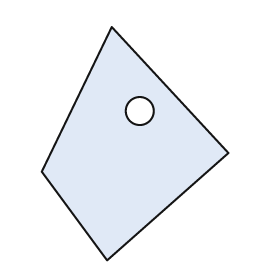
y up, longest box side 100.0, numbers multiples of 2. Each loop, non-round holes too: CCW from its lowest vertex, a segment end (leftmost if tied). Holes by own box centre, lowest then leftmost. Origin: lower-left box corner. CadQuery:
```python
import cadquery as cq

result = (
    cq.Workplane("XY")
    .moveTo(28.0, 0.0)
    .lineTo(80.0, 46.0)
    .lineTo(30.0, 100.0)
    .lineTo(0.0, 38.0)
    .close()
    .moveTo(42.0, 64.0)
    .circle(6.0)
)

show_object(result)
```